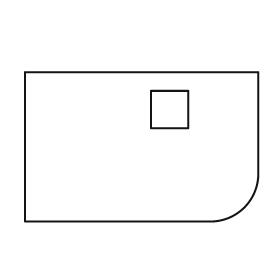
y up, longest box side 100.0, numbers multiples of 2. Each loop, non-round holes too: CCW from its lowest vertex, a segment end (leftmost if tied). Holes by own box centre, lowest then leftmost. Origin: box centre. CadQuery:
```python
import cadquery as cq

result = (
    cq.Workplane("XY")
    .moveTo(-50.0, -32.0)
    .lineTo(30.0, -32.0)
    .threePointArc((44.0, -26.0), (50.0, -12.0))
    .lineTo(50.0, 32.0)
    .lineTo(-50.0, 32.0)
    .close()
    .moveTo(4.0, 8.0)
    .lineTo(20.0, 8.0)
    .lineTo(20.0, 24.0)
    .lineTo(4.0, 24.0)
    .close()
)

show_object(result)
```